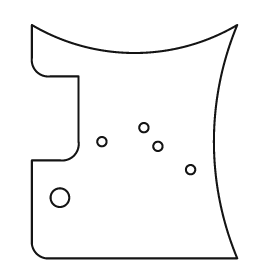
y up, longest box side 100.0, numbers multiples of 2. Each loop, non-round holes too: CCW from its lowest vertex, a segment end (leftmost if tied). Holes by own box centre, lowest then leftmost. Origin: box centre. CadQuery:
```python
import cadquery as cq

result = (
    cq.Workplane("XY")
    .moveTo(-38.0, -50.0)
    .lineTo(44.0, -50.0)
    .threePointArc((34.0, 0.0), (44.0, 50.0))
    .threePointArc((0.0, 38.0), (-44.0, 50.0))
    .lineTo(-44.0, 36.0)
    .threePointArc((-42.0, 30.0), (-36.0, 28.0))
    .lineTo(-24.0, 28.0)
    .lineTo(-24.0, 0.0)
    .threePointArc((-26.0, -6.0), (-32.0, -8.0))
    .lineTo(-44.0, -8.0)
    .lineTo(-44.0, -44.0)
    .threePointArc((-42.0, -48.0), (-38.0, -50.0))
    .close()
    .moveTo(-32.0, -24.0)
    .circle(4.0)
    .moveTo(24.0, -12.0)
    .circle(2.0)
    .moveTo(10.0, -2.0)
    .circle(2.0)
    .moveTo(-14.0, 0.0)
    .circle(2.0)
    .moveTo(4.0, 6.0)
    .circle(2.0)
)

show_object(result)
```